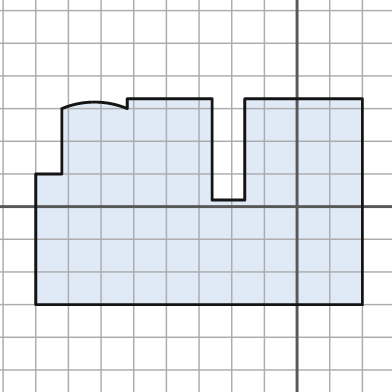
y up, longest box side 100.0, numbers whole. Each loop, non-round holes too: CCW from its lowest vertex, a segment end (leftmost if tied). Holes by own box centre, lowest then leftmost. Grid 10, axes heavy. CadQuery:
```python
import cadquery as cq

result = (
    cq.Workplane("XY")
    .moveTo(-80.0, -30.0)
    .lineTo(20.0, -30.0)
    .lineTo(20.0, 33.0)
    .lineTo(-16.0, 33.0)
    .lineTo(-16.0, 2.0)
    .lineTo(-26.0, 2.0)
    .lineTo(-26.0, 33.0)
    .lineTo(-52.0, 33.0)
    .lineTo(-52.0, 30.0)
    .threePointArc((-62.0, 32.0), (-72.0, 30.0))
    .lineTo(-72.0, 10.0)
    .lineTo(-80.0, 10.0)
    .close()
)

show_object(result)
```